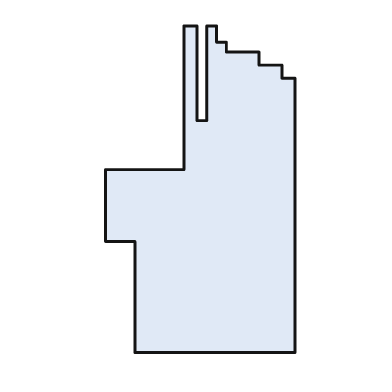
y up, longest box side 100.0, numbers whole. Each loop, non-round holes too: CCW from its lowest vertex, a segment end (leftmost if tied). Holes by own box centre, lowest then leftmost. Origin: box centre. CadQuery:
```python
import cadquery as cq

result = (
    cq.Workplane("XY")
    .moveTo(-20.0, -50.0)
    .lineTo(29.0, -50.0)
    .lineTo(29.0, 34.0)
    .lineTo(25.0, 34.0)
    .lineTo(25.0, 38.0)
    .lineTo(18.0, 38.0)
    .lineTo(18.0, 42.0)
    .lineTo(8.0, 42.0)
    .lineTo(8.0, 45.0)
    .lineTo(5.0, 45.0)
    .lineTo(5.0, 50.0)
    .lineTo(2.0, 50.0)
    .lineTo(2.0, 21.0)
    .lineTo(-1.0, 21.0)
    .lineTo(-1.0, 50.0)
    .lineTo(-5.0, 50.0)
    .lineTo(-5.0, 6.0)
    .lineTo(-29.0, 6.0)
    .lineTo(-29.0, -16.0)
    .lineTo(-20.0, -16.0)
    .close()
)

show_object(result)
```